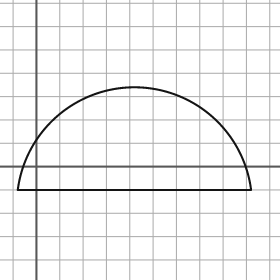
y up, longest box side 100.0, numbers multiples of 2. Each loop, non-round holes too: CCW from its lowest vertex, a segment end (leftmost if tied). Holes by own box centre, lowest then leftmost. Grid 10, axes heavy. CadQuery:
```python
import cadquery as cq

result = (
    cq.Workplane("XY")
    .moveTo(-8.0, -10.0)
    .lineTo(92.0, -10.0)
    .threePointArc((42.0, 34.0), (-8.0, -10.0))
    .close()
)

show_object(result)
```